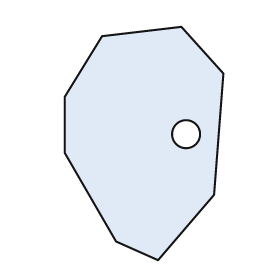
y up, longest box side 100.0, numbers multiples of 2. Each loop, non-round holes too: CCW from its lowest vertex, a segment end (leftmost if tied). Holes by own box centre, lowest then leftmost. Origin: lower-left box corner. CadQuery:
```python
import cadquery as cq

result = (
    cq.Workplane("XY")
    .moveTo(40.0, 0.0)
    .lineTo(64.0, 28.0)
    .lineTo(68.0, 80.0)
    .lineTo(50.0, 100.0)
    .lineTo(16.0, 96.0)
    .lineTo(0.0, 70.0)
    .lineTo(0.0, 46.0)
    .lineTo(22.0, 8.0)
    .close()
    .moveTo(52.0, 54.0)
    .circle(6.0)
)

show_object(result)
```